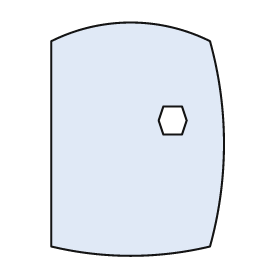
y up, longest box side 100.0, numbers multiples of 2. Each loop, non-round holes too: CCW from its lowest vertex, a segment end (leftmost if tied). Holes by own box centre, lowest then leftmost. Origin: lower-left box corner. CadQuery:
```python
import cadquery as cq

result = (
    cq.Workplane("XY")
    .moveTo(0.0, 4.0)
    .threePointArc((34.0, 0.0), (68.0, 4.0))
    .threePointArc((74.0, 48.0), (68.0, 92.0))
    .threePointArc((34.0, 100.0), (0.0, 92.0))
    .close()
    .moveTo(48.0, 52.0)
    .lineTo(56.0, 52.0)
    .lineTo(58.0, 58.0)
    .lineTo(56.0, 64.0)
    .lineTo(48.0, 64.0)
    .lineTo(46.0, 58.0)
    .close()
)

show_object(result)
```